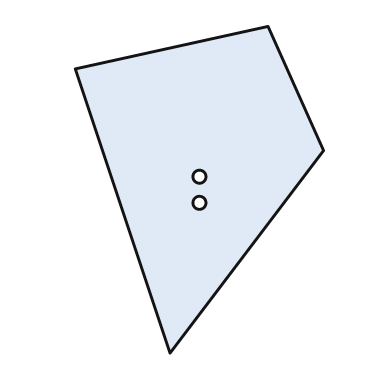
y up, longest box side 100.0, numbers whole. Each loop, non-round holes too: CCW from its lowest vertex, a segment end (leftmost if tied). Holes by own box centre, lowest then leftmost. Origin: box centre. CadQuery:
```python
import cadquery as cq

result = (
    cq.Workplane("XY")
    .moveTo(-9.0, -50.0)
    .lineTo(38.0, 12.0)
    .lineTo(21.0, 50.0)
    .lineTo(-38.0, 37.0)
    .close()
    .moveTo(0.0, -4.0)
    .circle(2.0)
    .moveTo(0.0, 4.0)
    .circle(2.0)
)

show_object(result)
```